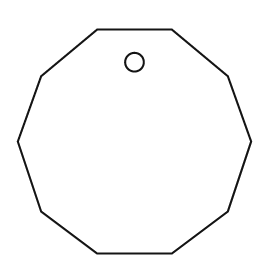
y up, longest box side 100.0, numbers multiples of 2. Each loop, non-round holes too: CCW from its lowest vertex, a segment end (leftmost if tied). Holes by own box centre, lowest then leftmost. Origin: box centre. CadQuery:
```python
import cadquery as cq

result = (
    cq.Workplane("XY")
    .moveTo(-16.0, -48.0)
    .lineTo(16.0, -48.0)
    .lineTo(40.0, -30.0)
    .lineTo(50.0, 0.0)
    .lineTo(40.0, 28.0)
    .lineTo(16.0, 48.0)
    .lineTo(-16.0, 48.0)
    .lineTo(-40.0, 28.0)
    .lineTo(-50.0, 0.0)
    .lineTo(-40.0, -30.0)
    .close()
    .moveTo(0.0, 34.0)
    .circle(4.0)
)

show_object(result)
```